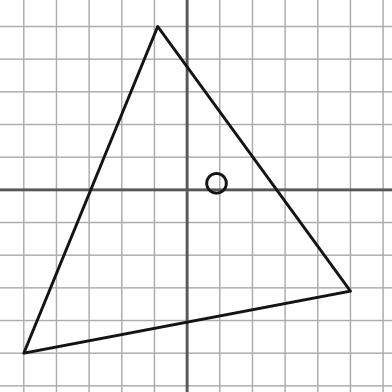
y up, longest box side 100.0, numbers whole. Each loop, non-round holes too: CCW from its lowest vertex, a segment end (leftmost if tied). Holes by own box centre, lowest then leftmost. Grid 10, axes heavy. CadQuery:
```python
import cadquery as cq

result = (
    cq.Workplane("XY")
    .moveTo(-50.0, -50.0)
    .lineTo(50.0, -31.0)
    .lineTo(-9.0, 50.0)
    .close()
    .moveTo(9.0, 2.0)
    .circle(3.0)
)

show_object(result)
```